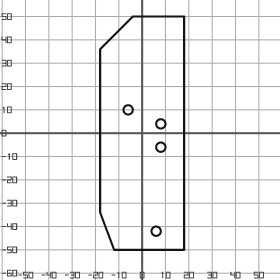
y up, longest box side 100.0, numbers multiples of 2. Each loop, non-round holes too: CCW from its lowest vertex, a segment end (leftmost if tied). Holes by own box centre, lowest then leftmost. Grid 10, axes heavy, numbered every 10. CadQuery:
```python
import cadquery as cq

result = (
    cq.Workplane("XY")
    .moveTo(-12.0, -50.0)
    .lineTo(18.0, -50.0)
    .lineTo(18.0, 50.0)
    .lineTo(-4.0, 50.0)
    .lineTo(-18.0, 36.0)
    .lineTo(-18.0, -34.0)
    .close()
    .moveTo(6.0, -42.0)
    .circle(2.0)
    .moveTo(8.0, -6.0)
    .circle(2.0)
    .moveTo(8.0, 4.0)
    .circle(2.0)
    .moveTo(-6.0, 10.0)
    .circle(2.0)
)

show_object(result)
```